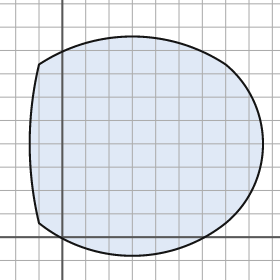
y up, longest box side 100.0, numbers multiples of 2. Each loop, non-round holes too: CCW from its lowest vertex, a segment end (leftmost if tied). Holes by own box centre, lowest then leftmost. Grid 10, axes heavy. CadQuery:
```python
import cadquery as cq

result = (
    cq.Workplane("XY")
    .moveTo(-10.0, 6.0)
    .threePointArc((30.0, -8.0), (70.0, 6.0))
    .threePointArc((86.0, 40.0), (70.0, 74.0))
    .threePointArc((30.0, 86.0), (-10.0, 74.0))
    .threePointArc((-14.0, 40.0), (-10.0, 6.0))
    .close()
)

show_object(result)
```